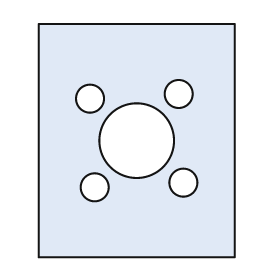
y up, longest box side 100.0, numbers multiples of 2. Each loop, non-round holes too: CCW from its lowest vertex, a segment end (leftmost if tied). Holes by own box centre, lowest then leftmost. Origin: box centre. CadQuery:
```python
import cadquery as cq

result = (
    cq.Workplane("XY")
    .moveTo(-42.0, -50.0)
    .lineTo(42.0, -50.0)
    .lineTo(42.0, 50.0)
    .lineTo(-42.0, 50.0)
    .close()
    .moveTo(-18.0, -20.0)
    .circle(6.0)
    .moveTo(20.0, -18.0)
    .circle(6.0)
    .moveTo(0.0, 0.0)
    .circle(16.0)
    .moveTo(-20.0, 18.0)
    .circle(6.0)
    .moveTo(18.0, 20.0)
    .circle(6.0)
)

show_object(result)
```